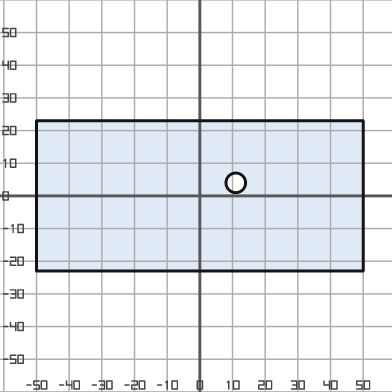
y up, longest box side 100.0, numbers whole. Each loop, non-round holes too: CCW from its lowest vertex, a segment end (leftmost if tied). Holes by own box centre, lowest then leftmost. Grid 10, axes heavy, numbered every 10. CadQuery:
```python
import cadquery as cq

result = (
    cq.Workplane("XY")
    .moveTo(-50.0, -23.0)
    .lineTo(50.0, -23.0)
    .lineTo(50.0, 23.0)
    .lineTo(-50.0, 23.0)
    .close()
    .moveTo(11.0, 4.0)
    .circle(3.0)
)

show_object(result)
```